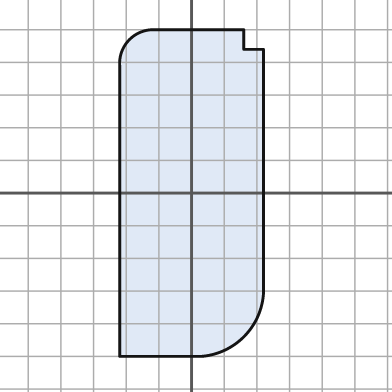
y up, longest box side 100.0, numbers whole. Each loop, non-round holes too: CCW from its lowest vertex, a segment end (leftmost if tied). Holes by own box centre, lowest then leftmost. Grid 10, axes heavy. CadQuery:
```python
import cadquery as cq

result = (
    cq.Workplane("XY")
    .moveTo(-22.0, -50.0)
    .lineTo(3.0, -50.0)
    .threePointArc((16.0, -44.0), (22.0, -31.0))
    .lineTo(22.0, 44.0)
    .lineTo(16.0, 44.0)
    .lineTo(16.0, 50.0)
    .lineTo(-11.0, 50.0)
    .threePointArc((-19.0, 47.0), (-22.0, 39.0))
    .close()
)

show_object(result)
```